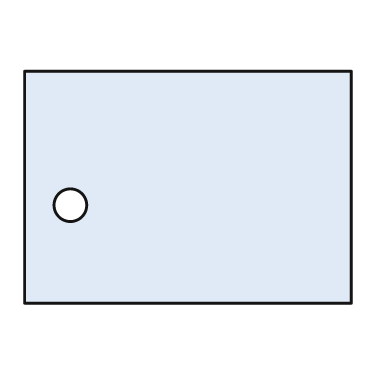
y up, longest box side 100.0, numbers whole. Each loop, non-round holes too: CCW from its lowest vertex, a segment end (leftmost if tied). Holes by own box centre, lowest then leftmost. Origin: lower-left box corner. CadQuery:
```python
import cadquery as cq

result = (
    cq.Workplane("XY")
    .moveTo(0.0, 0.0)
    .lineTo(100.0, 0.0)
    .lineTo(100.0, 71.0)
    .lineTo(0.0, 71.0)
    .close()
    .moveTo(14.0, 30.0)
    .circle(5.0)
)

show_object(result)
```